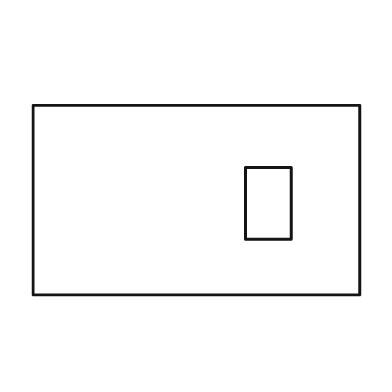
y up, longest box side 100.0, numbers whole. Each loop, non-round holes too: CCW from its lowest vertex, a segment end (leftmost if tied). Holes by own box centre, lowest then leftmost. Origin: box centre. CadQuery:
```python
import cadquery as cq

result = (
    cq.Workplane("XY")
    .moveTo(-50.0, -29.0)
    .lineTo(50.0, -29.0)
    .lineTo(50.0, 29.0)
    .lineTo(-50.0, 29.0)
    .close()
    .moveTo(15.0, -12.0)
    .lineTo(29.0, -12.0)
    .lineTo(29.0, 10.0)
    .lineTo(15.0, 10.0)
    .close()
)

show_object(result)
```